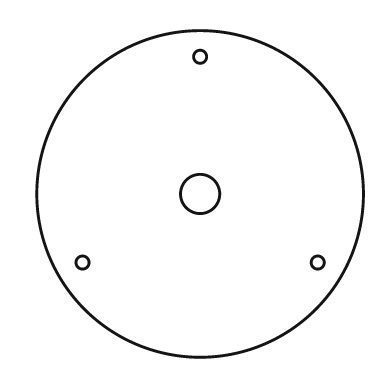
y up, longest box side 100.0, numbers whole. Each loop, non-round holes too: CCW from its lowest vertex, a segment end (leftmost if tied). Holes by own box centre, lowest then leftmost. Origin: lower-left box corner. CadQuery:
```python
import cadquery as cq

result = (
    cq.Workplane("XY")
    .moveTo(50.0, 50.0)
    .circle(50.0)
    .moveTo(14.0, 29.0)
    .circle(2.0)
    .moveTo(86.0, 29.0)
    .circle(2.0)
    .moveTo(50.0, 50.0)
    .circle(6.0)
    .moveTo(50.0, 92.0)
    .circle(2.0)
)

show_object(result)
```